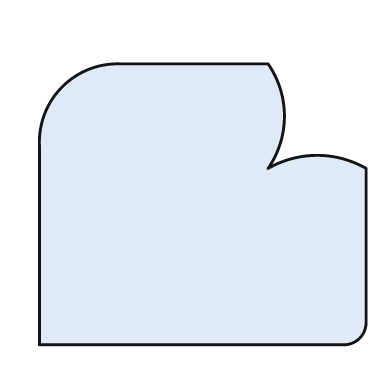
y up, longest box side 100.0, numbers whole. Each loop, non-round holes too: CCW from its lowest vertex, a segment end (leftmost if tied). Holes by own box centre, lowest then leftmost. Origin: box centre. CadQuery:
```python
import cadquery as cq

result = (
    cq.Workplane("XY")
    .moveTo(-50.0, -43.0)
    .lineTo(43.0, -43.0)
    .threePointArc((48.0, -41.0), (50.0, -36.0))
    .lineTo(50.0, 11.0)
    .threePointArc((35.0, 15.0), (20.0, 11.0))
    .threePointArc((25.0, 27.0), (20.0, 43.0))
    .lineTo(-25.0, 43.0)
    .threePointArc((-43.0, 36.0), (-50.0, 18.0))
    .close()
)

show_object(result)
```